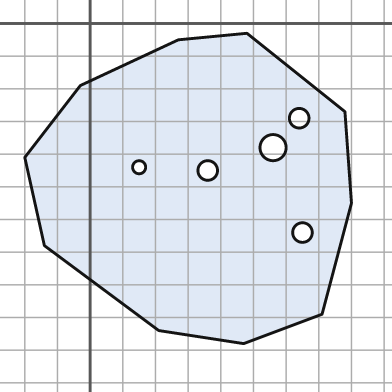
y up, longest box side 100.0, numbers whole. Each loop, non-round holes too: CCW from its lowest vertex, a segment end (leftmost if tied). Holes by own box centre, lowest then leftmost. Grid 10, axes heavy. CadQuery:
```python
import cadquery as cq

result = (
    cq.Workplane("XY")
    .moveTo(47.0, -98.0)
    .lineTo(71.0, -89.0)
    .lineTo(80.0, -55.0)
    .lineTo(78.0, -27.0)
    .lineTo(48.0, -3.0)
    .lineTo(27.0, -5.0)
    .lineTo(-3.0, -19.0)
    .lineTo(-20.0, -41.0)
    .lineTo(-14.0, -68.0)
    .lineTo(21.0, -94.0)
    .close()
    .moveTo(65.0, -64.0)
    .circle(3.0)
    .moveTo(36.0, -45.0)
    .circle(3.0)
    .moveTo(15.0, -44.0)
    .circle(2.0)
    .moveTo(56.0, -38.0)
    .circle(4.0)
    .moveTo(64.0, -29.0)
    .circle(3.0)
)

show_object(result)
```